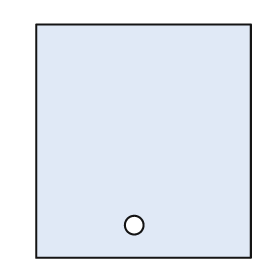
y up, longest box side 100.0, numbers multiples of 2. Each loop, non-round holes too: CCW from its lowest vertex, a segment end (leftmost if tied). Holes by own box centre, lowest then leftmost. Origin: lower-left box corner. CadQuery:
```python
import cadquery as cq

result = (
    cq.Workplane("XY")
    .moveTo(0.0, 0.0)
    .lineTo(92.0, 0.0)
    .lineTo(92.0, 100.0)
    .lineTo(0.0, 100.0)
    .close()
    .moveTo(42.0, 14.0)
    .circle(4.0)
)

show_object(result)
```